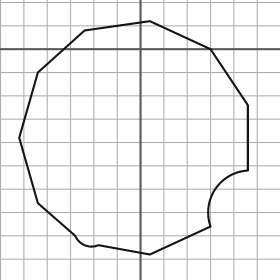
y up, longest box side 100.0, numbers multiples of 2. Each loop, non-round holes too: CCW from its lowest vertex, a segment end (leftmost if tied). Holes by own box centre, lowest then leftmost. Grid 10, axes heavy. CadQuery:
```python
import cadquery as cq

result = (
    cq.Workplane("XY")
    .moveTo(4.0, -88.0)
    .lineTo(30.0, -76.0)
    .threePointArc((32.0, -60.0), (46.0, -52.0))
    .lineTo(46.0, -24.0)
    .lineTo(30.0, 0.0)
    .lineTo(4.0, 12.0)
    .lineTo(-24.0, 8.0)
    .lineTo(-44.0, -10.0)
    .lineTo(-52.0, -38.0)
    .lineTo(-44.0, -66.0)
    .lineTo(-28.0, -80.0)
    .threePointArc((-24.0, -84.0), (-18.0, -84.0))
    .close()
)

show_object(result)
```